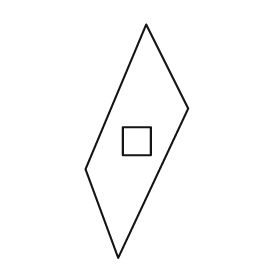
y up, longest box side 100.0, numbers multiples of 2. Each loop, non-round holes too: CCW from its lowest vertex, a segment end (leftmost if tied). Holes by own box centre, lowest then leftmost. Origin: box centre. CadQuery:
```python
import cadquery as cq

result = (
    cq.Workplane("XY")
    .moveTo(-8.0, -50.0)
    .lineTo(22.0, 14.0)
    .lineTo(4.0, 50.0)
    .lineTo(-22.0, -12.0)
    .close()
    .moveTo(-6.0, -6.0)
    .lineTo(6.0, -6.0)
    .lineTo(6.0, 6.0)
    .lineTo(-6.0, 6.0)
    .close()
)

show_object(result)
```